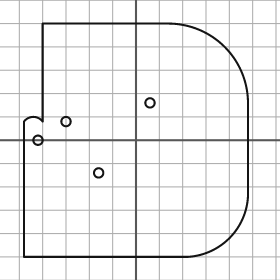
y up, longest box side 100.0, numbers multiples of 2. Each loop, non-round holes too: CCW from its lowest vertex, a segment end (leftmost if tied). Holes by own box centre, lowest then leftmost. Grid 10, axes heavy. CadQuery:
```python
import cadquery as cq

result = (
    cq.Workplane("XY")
    .moveTo(-48.0, -50.0)
    .lineTo(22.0, -50.0)
    .threePointArc((40.0, -42.0), (48.0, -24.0))
    .lineTo(48.0, 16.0)
    .threePointArc((38.0, 40.0), (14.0, 50.0))
    .lineTo(-40.0, 50.0)
    .lineTo(-40.0, 8.0)
    .threePointArc((-44.0, 10.0), (-48.0, 8.0))
    .close()
    .moveTo(-16.0, -14.0)
    .circle(2.0)
    .moveTo(-42.0, 0.0)
    .circle(2.0)
    .moveTo(-30.0, 8.0)
    .circle(2.0)
    .moveTo(6.0, 16.0)
    .circle(2.0)
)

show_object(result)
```